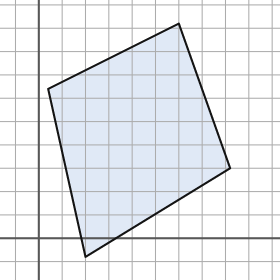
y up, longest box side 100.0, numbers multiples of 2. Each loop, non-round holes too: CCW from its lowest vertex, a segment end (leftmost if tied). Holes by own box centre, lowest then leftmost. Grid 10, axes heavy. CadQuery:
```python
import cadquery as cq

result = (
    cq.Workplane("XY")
    .moveTo(20.0, -8.0)
    .lineTo(82.0, 30.0)
    .lineTo(60.0, 92.0)
    .lineTo(4.0, 64.0)
    .close()
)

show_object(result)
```